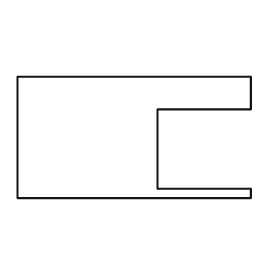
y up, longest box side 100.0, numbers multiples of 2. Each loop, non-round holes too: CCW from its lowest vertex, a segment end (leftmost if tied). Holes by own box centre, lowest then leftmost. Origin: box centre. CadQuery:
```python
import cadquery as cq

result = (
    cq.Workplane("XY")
    .moveTo(-50.0, -26.0)
    .lineTo(50.0, -26.0)
    .lineTo(50.0, -22.0)
    .lineTo(10.0, -22.0)
    .lineTo(10.0, 12.0)
    .lineTo(50.0, 12.0)
    .lineTo(50.0, 26.0)
    .lineTo(-50.0, 26.0)
    .close()
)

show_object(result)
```